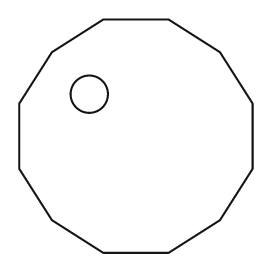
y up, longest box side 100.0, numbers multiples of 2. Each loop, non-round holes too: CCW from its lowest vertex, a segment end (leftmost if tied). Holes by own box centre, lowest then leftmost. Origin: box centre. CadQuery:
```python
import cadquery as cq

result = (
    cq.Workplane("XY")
    .moveTo(-14.0, -50.0)
    .lineTo(14.0, -50.0)
    .lineTo(36.0, -36.0)
    .lineTo(50.0, -14.0)
    .lineTo(50.0, 14.0)
    .lineTo(36.0, 36.0)
    .lineTo(14.0, 50.0)
    .lineTo(-14.0, 50.0)
    .lineTo(-36.0, 36.0)
    .lineTo(-50.0, 14.0)
    .lineTo(-50.0, -14.0)
    .lineTo(-36.0, -36.0)
    .close()
    .moveTo(-20.0, 18.0)
    .circle(8.0)
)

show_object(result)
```